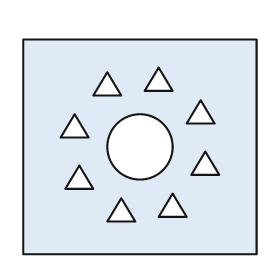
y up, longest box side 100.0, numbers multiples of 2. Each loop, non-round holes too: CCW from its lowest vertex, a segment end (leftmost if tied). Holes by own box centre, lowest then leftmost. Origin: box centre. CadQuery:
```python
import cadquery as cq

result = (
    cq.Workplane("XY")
    .moveTo(-50.0, -46.0)
    .lineTo(50.0, -46.0)
    .lineTo(50.0, 46.0)
    .lineTo(-50.0, 46.0)
    .close()
    .moveTo(-14.0, -32.0)
    .lineTo(-2.0, -32.0)
    .lineTo(-8.0, -22.0)
    .close()
    .moveTo(8.0, -30.0)
    .lineTo(20.0, -30.0)
    .lineTo(14.0, -20.0)
    .close()
    .moveTo(-32.0, -18.0)
    .lineTo(-20.0, -18.0)
    .lineTo(-26.0, -8.0)
    .close()
    .moveTo(22.0, -12.0)
    .lineTo(34.0, -12.0)
    .lineTo(28.0, -2.0)
    .close()
    .moveTo(0.0, 0.0)
    .circle(14.0)
    .moveTo(-34.0, 4.0)
    .lineTo(-22.0, 4.0)
    .lineTo(-28.0, 14.0)
    .close()
    .moveTo(20.0, 10.0)
    .lineTo(32.0, 10.0)
    .lineTo(26.0, 20.0)
    .close()
    .moveTo(-20.0, 22.0)
    .lineTo(-8.0, 22.0)
    .lineTo(-14.0, 32.0)
    .close()
    .moveTo(2.0, 24.0)
    .lineTo(14.0, 24.0)
    .lineTo(8.0, 34.0)
    .close()
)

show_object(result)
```